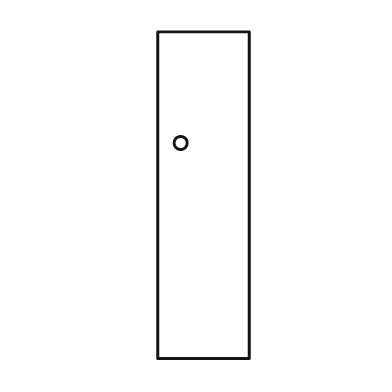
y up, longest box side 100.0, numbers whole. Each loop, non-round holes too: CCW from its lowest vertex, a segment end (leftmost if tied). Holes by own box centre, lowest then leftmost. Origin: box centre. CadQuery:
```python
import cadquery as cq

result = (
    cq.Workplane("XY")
    .moveTo(-14.0, -50.0)
    .lineTo(14.0, -50.0)
    .lineTo(14.0, 50.0)
    .lineTo(-14.0, 50.0)
    .close()
    .moveTo(-7.0, 16.0)
    .circle(2.0)
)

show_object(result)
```